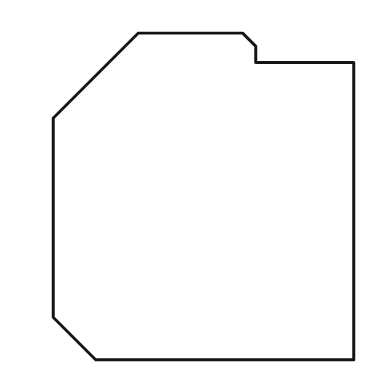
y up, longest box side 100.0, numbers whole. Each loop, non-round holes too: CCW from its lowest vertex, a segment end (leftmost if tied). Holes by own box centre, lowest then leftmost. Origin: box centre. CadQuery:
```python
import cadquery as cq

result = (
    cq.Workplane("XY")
    .moveTo(-33.0, -50.0)
    .lineTo(46.0, -50.0)
    .lineTo(46.0, 41.0)
    .lineTo(16.0, 41.0)
    .lineTo(16.0, 46.0)
    .lineTo(12.0, 50.0)
    .lineTo(-20.0, 50.0)
    .lineTo(-46.0, 24.0)
    .lineTo(-46.0, -37.0)
    .close()
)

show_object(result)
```